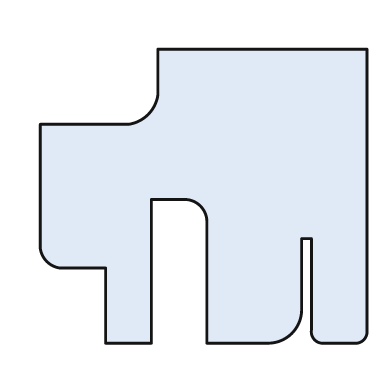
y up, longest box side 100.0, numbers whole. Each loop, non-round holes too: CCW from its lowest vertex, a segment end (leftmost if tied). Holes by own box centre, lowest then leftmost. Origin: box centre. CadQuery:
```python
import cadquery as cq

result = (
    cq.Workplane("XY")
    .moveTo(-30.0, -45.0)
    .lineTo(-16.0, -45.0)
    .lineTo(-16.0, -1.0)
    .lineTo(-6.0, -1.0)
    .threePointArc((-1.0, -3.0), (1.0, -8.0))
    .lineTo(1.0, -45.0)
    .lineTo(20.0, -45.0)
    .threePointArc((27.0, -42.0), (30.0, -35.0))
    .lineTo(30.0, -13.0)
    .lineTo(33.0, -13.0)
    .lineTo(33.0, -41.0)
    .threePointArc((34.0, -44.0), (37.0, -45.0))
    .lineTo(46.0, -45.0)
    .threePointArc((49.0, -44.0), (50.0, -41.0))
    .lineTo(50.0, 45.0)
    .lineTo(-14.0, 45.0)
    .lineTo(-14.0, 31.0)
    .threePointArc((-17.0, 25.0), (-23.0, 22.0))
    .lineTo(-50.0, 22.0)
    .lineTo(-50.0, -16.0)
    .threePointArc((-48.0, -20.0), (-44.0, -22.0))
    .lineTo(-30.0, -22.0)
    .close()
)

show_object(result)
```